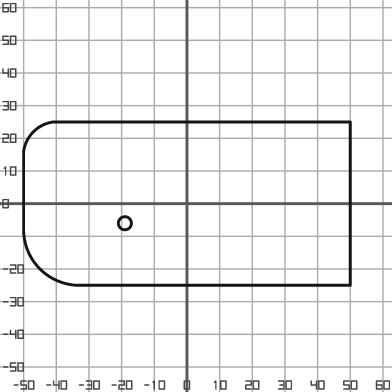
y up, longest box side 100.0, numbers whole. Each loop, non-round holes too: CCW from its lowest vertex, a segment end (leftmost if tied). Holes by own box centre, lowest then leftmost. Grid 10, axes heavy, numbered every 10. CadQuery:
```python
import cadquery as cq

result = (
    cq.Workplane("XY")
    .moveTo(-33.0, -25.0)
    .lineTo(50.0, -25.0)
    .lineTo(50.0, 25.0)
    .lineTo(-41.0, 25.0)
    .threePointArc((-47.0, 22.0), (-50.0, 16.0))
    .lineTo(-50.0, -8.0)
    .threePointArc((-45.0, -20.0), (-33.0, -25.0))
    .close()
    .moveTo(-19.0, -6.0)
    .circle(2.0)
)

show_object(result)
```